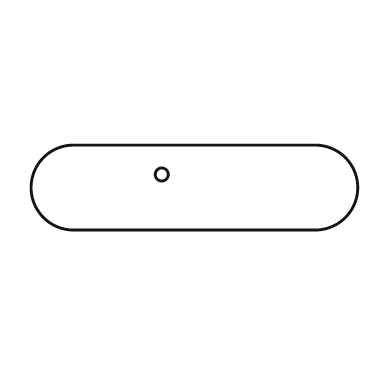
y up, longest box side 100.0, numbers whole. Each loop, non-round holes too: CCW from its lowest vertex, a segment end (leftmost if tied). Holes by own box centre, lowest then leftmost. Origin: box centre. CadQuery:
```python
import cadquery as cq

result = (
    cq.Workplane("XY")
    .moveTo(-37.0, -13.0)
    .lineTo(37.0, -13.0)
    .threePointArc((50.0, 0.0), (37.0, 13.0))
    .lineTo(-37.0, 13.0)
    .threePointArc((-50.0, 0.0), (-37.0, -13.0))
    .close()
    .moveTo(-10.0, 4.0)
    .circle(2.0)
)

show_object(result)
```